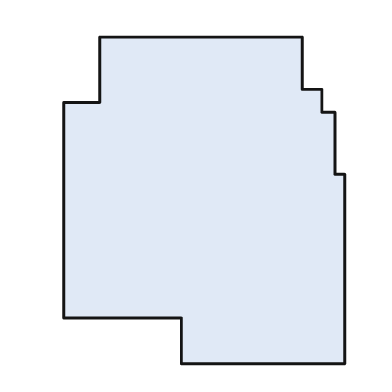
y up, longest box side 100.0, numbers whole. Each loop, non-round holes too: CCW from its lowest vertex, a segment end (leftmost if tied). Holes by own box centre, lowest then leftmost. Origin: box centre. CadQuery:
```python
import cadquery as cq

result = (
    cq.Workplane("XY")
    .moveTo(-7.0, -50.0)
    .lineTo(43.0, -50.0)
    .lineTo(43.0, 8.0)
    .lineTo(40.0, 8.0)
    .lineTo(40.0, 27.0)
    .lineTo(36.0, 27.0)
    .lineTo(36.0, 34.0)
    .lineTo(30.0, 34.0)
    .lineTo(30.0, 50.0)
    .lineTo(-32.0, 50.0)
    .lineTo(-32.0, 30.0)
    .lineTo(-43.0, 30.0)
    .lineTo(-43.0, -36.0)
    .lineTo(-7.0, -36.0)
    .close()
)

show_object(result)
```